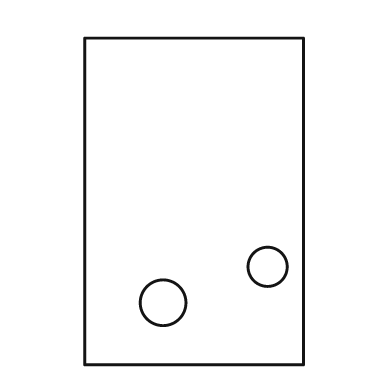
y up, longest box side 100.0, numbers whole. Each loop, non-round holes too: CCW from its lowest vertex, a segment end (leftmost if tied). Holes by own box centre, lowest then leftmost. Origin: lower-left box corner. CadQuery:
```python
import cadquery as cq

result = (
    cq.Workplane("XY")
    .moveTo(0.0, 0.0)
    .lineTo(67.0, 0.0)
    .lineTo(67.0, 100.0)
    .lineTo(0.0, 100.0)
    .close()
    .moveTo(24.0, 19.0)
    .circle(7.0)
    .moveTo(56.0, 30.0)
    .circle(6.0)
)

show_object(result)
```